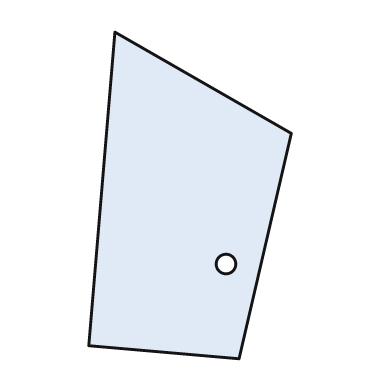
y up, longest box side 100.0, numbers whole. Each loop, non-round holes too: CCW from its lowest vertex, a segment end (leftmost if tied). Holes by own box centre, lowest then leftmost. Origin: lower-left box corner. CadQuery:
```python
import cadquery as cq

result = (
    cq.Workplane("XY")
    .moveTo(46.0, 0.0)
    .lineTo(62.0, 69.0)
    .lineTo(8.0, 100.0)
    .lineTo(0.0, 4.0)
    .close()
    .moveTo(42.0, 29.0)
    .circle(3.0)
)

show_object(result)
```